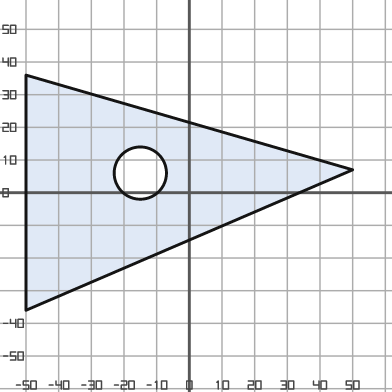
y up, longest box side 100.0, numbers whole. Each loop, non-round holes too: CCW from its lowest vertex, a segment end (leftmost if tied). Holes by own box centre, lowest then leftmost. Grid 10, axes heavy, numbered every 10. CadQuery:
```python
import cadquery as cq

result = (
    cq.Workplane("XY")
    .moveTo(-50.0, -36.0)
    .lineTo(50.0, 7.0)
    .lineTo(-50.0, 36.0)
    .close()
    .moveTo(-15.0, 6.0)
    .circle(8.0)
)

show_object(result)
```